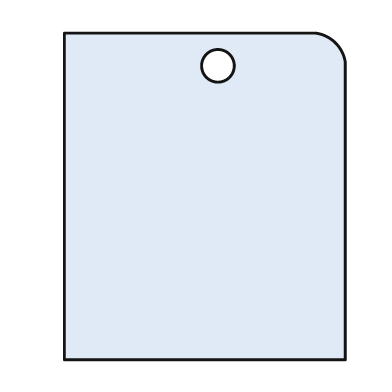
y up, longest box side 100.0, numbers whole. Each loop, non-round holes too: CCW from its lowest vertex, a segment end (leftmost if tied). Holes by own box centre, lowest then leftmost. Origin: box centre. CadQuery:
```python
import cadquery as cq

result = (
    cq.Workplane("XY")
    .moveTo(-43.0, -50.0)
    .lineTo(43.0, -50.0)
    .lineTo(43.0, 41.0)
    .threePointArc((40.0, 47.0), (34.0, 50.0))
    .lineTo(-43.0, 50.0)
    .close()
    .moveTo(4.0, 40.0)
    .circle(5.0)
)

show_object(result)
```